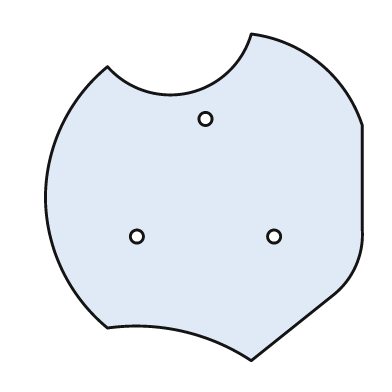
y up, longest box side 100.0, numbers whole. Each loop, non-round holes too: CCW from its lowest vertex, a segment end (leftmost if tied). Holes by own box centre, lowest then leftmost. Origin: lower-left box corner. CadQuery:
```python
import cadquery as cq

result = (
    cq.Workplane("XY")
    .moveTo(63.0, 0.0)
    .lineTo(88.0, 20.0)
    .threePointArc((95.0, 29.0), (97.0, 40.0))
    .lineTo(97.0, 72.0)
    .threePointArc((84.0, 91.0), (63.0, 100.0))
    .threePointArc((44.0, 82.0), (19.0, 90.0))
    .threePointArc((5.0, 72.0), (0.0, 50.0))
    .threePointArc((5.0, 28.0), (19.0, 10.0))
    .threePointArc((42.0, 9.0), (63.0, 0.0))
    .close()
    .moveTo(28.0, 38.0)
    .circle(2.0)
    .moveTo(70.0, 38.0)
    .circle(2.0)
    .moveTo(49.0, 74.0)
    .circle(2.0)
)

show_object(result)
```